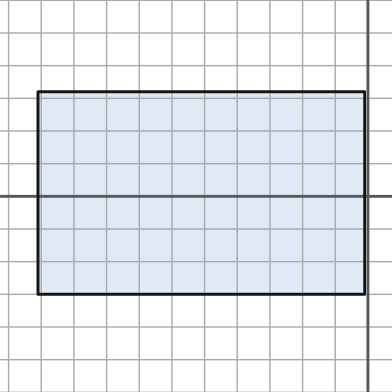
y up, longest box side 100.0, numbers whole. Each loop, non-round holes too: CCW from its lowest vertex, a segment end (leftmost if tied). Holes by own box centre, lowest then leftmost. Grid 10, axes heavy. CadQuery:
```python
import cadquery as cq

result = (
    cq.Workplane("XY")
    .moveTo(-101.0, -30.0)
    .lineTo(-1.0, -30.0)
    .lineTo(-1.0, 32.0)
    .lineTo(-101.0, 32.0)
    .close()
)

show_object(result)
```